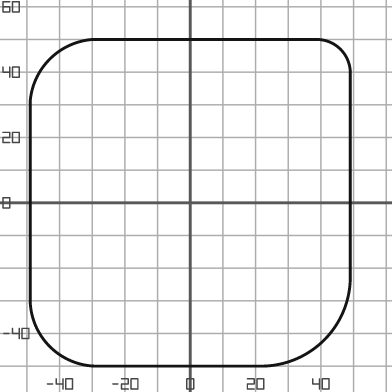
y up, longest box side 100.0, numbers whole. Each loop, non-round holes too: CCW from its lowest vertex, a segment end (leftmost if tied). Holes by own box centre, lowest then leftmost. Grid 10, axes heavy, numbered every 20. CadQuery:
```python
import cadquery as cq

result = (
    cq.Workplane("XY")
    .moveTo(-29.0, -50.0)
    .lineTo(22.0, -50.0)
    .threePointArc((41.0, -42.0), (49.0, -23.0))
    .lineTo(49.0, 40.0)
    .threePointArc((46.0, 47.0), (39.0, 50.0))
    .lineTo(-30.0, 50.0)
    .threePointArc((-43.0, 44.0), (-49.0, 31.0))
    .lineTo(-49.0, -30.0)
    .threePointArc((-43.0, -44.0), (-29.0, -50.0))
    .close()
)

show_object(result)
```